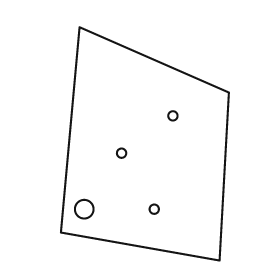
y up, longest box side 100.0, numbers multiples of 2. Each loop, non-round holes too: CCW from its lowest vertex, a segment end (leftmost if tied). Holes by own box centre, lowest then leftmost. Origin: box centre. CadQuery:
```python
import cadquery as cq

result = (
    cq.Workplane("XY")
    .moveTo(32.0, -50.0)
    .lineTo(36.0, 22.0)
    .lineTo(-28.0, 50.0)
    .lineTo(-36.0, -38.0)
    .close()
    .moveTo(-26.0, -28.0)
    .circle(4.0)
    .moveTo(4.0, -28.0)
    .circle(2.0)
    .moveTo(-10.0, -4.0)
    .circle(2.0)
    .moveTo(12.0, 12.0)
    .circle(2.0)
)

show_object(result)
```